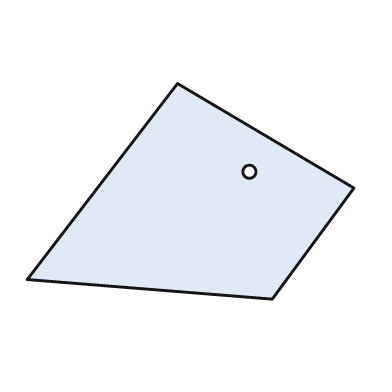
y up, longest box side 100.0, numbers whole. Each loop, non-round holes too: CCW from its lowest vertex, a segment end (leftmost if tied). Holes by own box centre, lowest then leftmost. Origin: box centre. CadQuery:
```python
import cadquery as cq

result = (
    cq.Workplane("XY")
    .moveTo(25.0, -33.0)
    .lineTo(50.0, 1.0)
    .lineTo(-4.0, 33.0)
    .lineTo(-50.0, -27.0)
    .close()
    .moveTo(18.0, 6.0)
    .circle(2.0)
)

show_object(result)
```